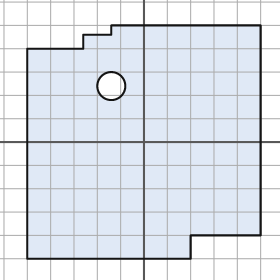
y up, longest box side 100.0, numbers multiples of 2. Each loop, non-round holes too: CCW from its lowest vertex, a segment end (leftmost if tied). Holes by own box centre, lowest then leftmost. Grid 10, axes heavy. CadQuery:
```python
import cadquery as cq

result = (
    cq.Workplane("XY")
    .moveTo(-50.0, -50.0)
    .lineTo(20.0, -50.0)
    .lineTo(20.0, -40.0)
    .lineTo(50.0, -40.0)
    .lineTo(50.0, 50.0)
    .lineTo(-14.0, 50.0)
    .lineTo(-14.0, 46.0)
    .lineTo(-26.0, 46.0)
    .lineTo(-26.0, 40.0)
    .lineTo(-50.0, 40.0)
    .close()
    .moveTo(-14.0, 24.0)
    .circle(6.0)
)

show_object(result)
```